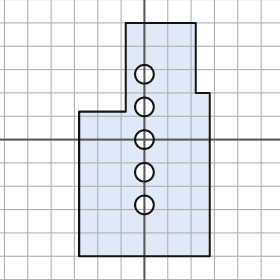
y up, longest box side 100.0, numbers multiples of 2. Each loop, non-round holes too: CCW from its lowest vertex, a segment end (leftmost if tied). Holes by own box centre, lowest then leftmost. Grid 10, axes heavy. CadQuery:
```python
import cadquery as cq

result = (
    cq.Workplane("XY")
    .moveTo(-28.0, -50.0)
    .lineTo(28.0, -50.0)
    .lineTo(28.0, 20.0)
    .lineTo(22.0, 20.0)
    .lineTo(22.0, 50.0)
    .lineTo(-8.0, 50.0)
    .lineTo(-8.0, 12.0)
    .lineTo(-28.0, 12.0)
    .close()
    .moveTo(0.0, -28.0)
    .circle(4.0)
    .moveTo(0.0, -14.0)
    .circle(4.0)
    .moveTo(0.0, 0.0)
    .circle(4.0)
    .moveTo(0.0, 14.0)
    .circle(4.0)
    .moveTo(0.0, 28.0)
    .circle(4.0)
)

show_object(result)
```